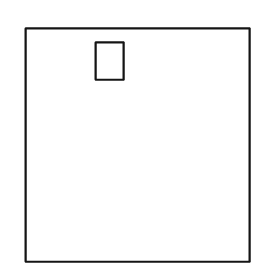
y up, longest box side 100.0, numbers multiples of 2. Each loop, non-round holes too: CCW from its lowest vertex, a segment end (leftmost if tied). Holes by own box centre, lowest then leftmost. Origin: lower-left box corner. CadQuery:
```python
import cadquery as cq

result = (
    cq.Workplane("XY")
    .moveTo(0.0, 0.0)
    .lineTo(96.0, 0.0)
    .lineTo(96.0, 100.0)
    .lineTo(0.0, 100.0)
    .close()
    .moveTo(30.0, 78.0)
    .lineTo(42.0, 78.0)
    .lineTo(42.0, 94.0)
    .lineTo(30.0, 94.0)
    .close()
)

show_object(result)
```